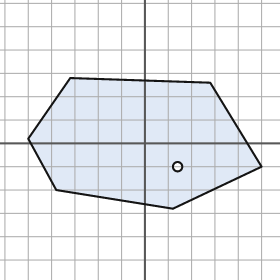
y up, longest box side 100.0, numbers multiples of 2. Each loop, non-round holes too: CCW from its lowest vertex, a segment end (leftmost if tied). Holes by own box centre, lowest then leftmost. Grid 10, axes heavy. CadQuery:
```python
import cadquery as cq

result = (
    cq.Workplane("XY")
    .moveTo(12.0, -28.0)
    .lineTo(50.0, -10.0)
    .lineTo(28.0, 26.0)
    .lineTo(-32.0, 28.0)
    .lineTo(-50.0, 2.0)
    .lineTo(-38.0, -20.0)
    .close()
    .moveTo(14.0, -10.0)
    .circle(2.0)
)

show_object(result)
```